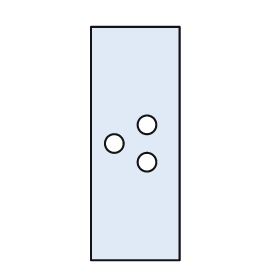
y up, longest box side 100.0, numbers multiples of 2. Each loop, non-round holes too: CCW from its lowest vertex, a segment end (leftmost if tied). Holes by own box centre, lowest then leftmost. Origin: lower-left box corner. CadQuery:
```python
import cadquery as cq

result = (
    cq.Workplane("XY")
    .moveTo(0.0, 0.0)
    .lineTo(38.0, 0.0)
    .lineTo(38.0, 100.0)
    .lineTo(0.0, 100.0)
    .close()
    .moveTo(24.0, 42.0)
    .circle(4.0)
    .moveTo(10.0, 50.0)
    .circle(4.0)
    .moveTo(24.0, 58.0)
    .circle(4.0)
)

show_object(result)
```